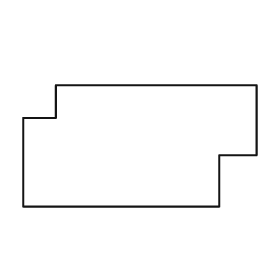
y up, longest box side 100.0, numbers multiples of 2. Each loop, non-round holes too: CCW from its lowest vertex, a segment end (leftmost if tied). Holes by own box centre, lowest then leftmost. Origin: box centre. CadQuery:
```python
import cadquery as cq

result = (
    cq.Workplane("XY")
    .moveTo(-50.0, -26.0)
    .lineTo(34.0, -26.0)
    .lineTo(34.0, -4.0)
    .lineTo(50.0, -4.0)
    .lineTo(50.0, 26.0)
    .lineTo(-36.0, 26.0)
    .lineTo(-36.0, 12.0)
    .lineTo(-50.0, 12.0)
    .close()
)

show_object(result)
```